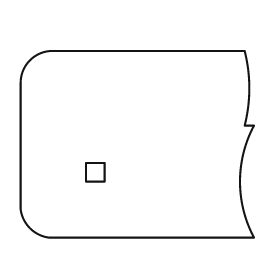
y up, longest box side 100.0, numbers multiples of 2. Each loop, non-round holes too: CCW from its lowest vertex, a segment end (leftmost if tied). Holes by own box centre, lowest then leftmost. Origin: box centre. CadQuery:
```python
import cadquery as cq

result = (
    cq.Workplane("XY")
    .moveTo(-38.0, -40.0)
    .lineTo(50.0, -40.0)
    .threePointArc((44.0, -16.0), (50.0, 8.0))
    .lineTo(46.0, 8.0)
    .threePointArc((48.0, 24.0), (46.0, 40.0))
    .lineTo(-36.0, 40.0)
    .threePointArc((-46.0, 36.0), (-50.0, 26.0))
    .lineTo(-50.0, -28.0)
    .threePointArc((-46.0, -36.0), (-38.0, -40.0))
    .close()
    .moveTo(-22.0, -16.0)
    .lineTo(-14.0, -16.0)
    .lineTo(-14.0, -8.0)
    .lineTo(-22.0, -8.0)
    .close()
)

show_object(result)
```